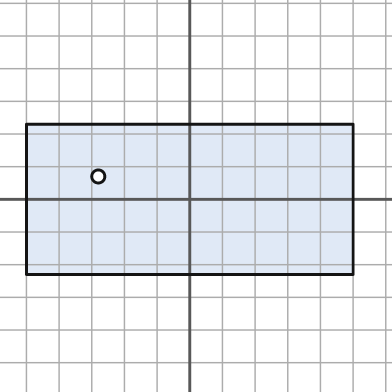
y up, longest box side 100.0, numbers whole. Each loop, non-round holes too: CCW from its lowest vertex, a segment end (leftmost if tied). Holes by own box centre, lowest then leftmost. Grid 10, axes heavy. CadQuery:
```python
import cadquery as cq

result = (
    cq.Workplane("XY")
    .moveTo(-50.0, -23.0)
    .lineTo(50.0, -23.0)
    .lineTo(50.0, 23.0)
    .lineTo(-50.0, 23.0)
    .close()
    .moveTo(-28.0, 7.0)
    .circle(2.0)
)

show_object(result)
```